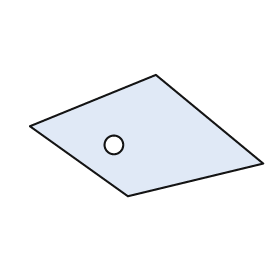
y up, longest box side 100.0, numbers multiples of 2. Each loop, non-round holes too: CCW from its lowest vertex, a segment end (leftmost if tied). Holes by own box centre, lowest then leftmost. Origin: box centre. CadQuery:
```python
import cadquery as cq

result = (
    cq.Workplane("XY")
    .moveTo(-8.0, -26.0)
    .lineTo(50.0, -12.0)
    .lineTo(4.0, 26.0)
    .lineTo(-50.0, 4.0)
    .close()
    .moveTo(-14.0, -4.0)
    .circle(4.0)
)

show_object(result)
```